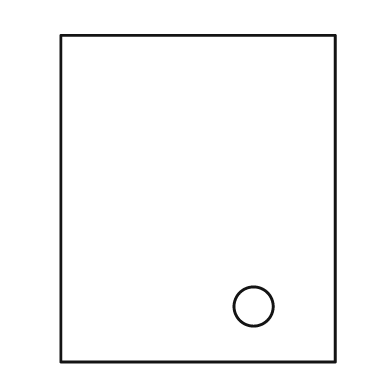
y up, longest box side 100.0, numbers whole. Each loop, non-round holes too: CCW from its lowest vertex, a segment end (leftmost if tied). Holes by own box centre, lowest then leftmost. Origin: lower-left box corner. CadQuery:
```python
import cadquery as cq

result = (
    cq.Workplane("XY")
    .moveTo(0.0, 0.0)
    .lineTo(84.0, 0.0)
    .lineTo(84.0, 100.0)
    .lineTo(0.0, 100.0)
    .close()
    .moveTo(59.0, 17.0)
    .circle(6.0)
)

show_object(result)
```